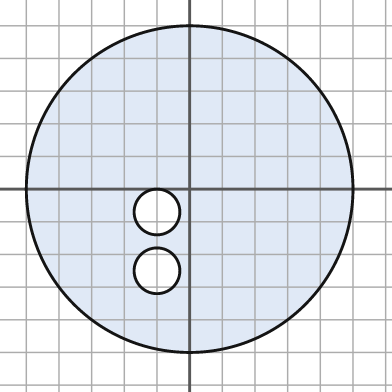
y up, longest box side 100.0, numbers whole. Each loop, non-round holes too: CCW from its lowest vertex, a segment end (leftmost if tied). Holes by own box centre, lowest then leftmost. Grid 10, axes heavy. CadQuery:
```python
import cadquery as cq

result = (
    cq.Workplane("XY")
    .moveTo(0.0, 0.0)
    .circle(50.0)
    .moveTo(-10.0, -25.0)
    .circle(7.0)
    .moveTo(-10.0, -7.0)
    .circle(7.0)
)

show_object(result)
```